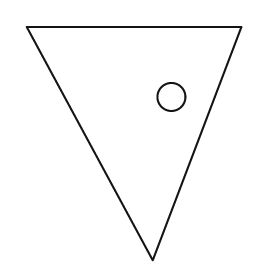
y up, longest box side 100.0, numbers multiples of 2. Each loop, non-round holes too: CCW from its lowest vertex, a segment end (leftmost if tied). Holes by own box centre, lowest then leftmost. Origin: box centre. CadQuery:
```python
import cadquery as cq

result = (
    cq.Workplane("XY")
    .moveTo(8.0, -50.0)
    .lineTo(46.0, 50.0)
    .lineTo(-46.0, 50.0)
    .close()
    .moveTo(16.0, 20.0)
    .circle(6.0)
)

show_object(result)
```